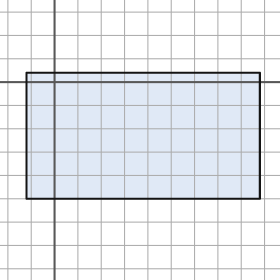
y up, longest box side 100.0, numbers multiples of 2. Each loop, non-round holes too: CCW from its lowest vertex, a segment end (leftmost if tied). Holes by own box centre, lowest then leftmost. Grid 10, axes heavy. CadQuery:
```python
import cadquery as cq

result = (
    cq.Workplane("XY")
    .moveTo(-12.0, -50.0)
    .lineTo(88.0, -50.0)
    .lineTo(88.0, 4.0)
    .lineTo(-12.0, 4.0)
    .close()
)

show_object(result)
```